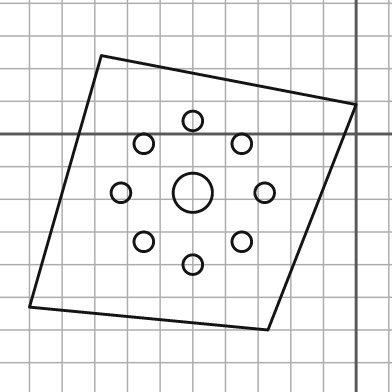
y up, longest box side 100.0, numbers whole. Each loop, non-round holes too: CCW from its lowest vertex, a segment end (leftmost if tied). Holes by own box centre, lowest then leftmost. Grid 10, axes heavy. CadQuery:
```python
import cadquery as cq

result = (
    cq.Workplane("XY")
    .moveTo(-27.0, -60.0)
    .lineTo(0.0, 9.0)
    .lineTo(-78.0, 24.0)
    .lineTo(-100.0, -53.0)
    .close()
    .moveTo(-50.0, -40.0)
    .circle(3.0)
    .moveTo(-65.0, -33.0)
    .circle(3.0)
    .moveTo(-35.0, -33.0)
    .circle(3.0)
    .moveTo(-72.0, -18.0)
    .circle(3.0)
    .moveTo(-50.0, -18.0)
    .circle(6.0)
    .moveTo(-28.0, -18.0)
    .circle(3.0)
    .moveTo(-65.0, -3.0)
    .circle(3.0)
    .moveTo(-35.0, -3.0)
    .circle(3.0)
    .moveTo(-50.0, 4.0)
    .circle(3.0)
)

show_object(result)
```